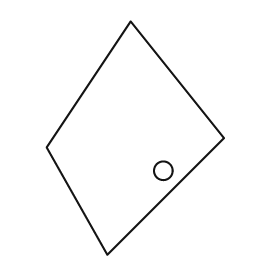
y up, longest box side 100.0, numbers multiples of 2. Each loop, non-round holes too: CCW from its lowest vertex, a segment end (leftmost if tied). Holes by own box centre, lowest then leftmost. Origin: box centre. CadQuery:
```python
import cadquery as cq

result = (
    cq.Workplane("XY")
    .moveTo(-12.0, -50.0)
    .lineTo(38.0, 0.0)
    .lineTo(-2.0, 50.0)
    .lineTo(-38.0, -4.0)
    .close()
    .moveTo(12.0, -14.0)
    .circle(4.0)
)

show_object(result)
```